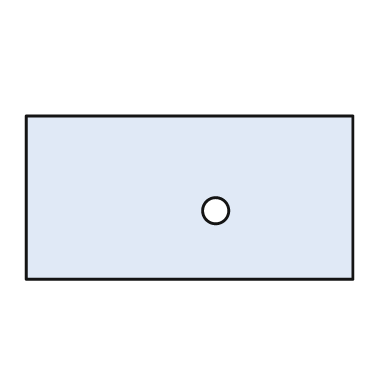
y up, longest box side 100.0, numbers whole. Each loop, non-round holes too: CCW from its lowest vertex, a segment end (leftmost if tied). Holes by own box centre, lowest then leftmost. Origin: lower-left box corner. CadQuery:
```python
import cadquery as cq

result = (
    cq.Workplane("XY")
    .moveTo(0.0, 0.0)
    .lineTo(100.0, 0.0)
    .lineTo(100.0, 50.0)
    .lineTo(0.0, 50.0)
    .close()
    .moveTo(58.0, 21.0)
    .circle(4.0)
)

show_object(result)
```